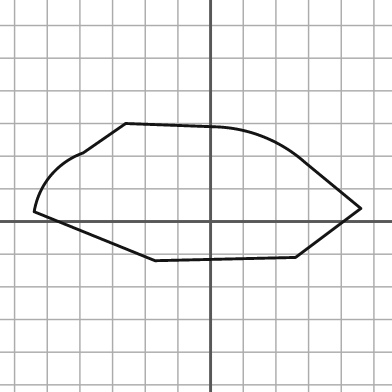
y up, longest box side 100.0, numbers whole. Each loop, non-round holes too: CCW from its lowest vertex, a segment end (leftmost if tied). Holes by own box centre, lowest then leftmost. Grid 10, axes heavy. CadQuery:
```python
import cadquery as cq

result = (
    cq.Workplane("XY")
    .moveTo(-17.0, -12.0)
    .lineTo(26.0, -11.0)
    .lineTo(46.0, 4.0)
    .lineTo(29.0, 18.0)
    .threePointArc((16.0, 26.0), (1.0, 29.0))
    .lineTo(-26.0, 30.0)
    .lineTo(-39.0, 21.0)
    .threePointArc((-49.0, 14.0), (-54.0, 3.0))
    .close()
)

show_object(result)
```